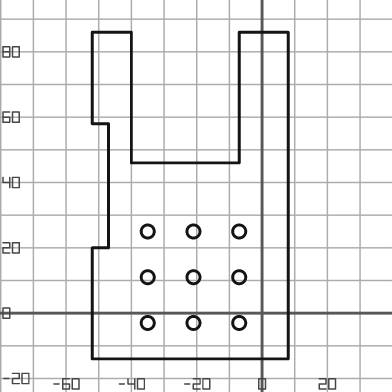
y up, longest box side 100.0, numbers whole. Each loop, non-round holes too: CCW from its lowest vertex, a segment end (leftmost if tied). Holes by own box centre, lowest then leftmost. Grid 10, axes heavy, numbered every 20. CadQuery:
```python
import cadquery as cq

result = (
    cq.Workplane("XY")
    .moveTo(-52.0, -14.0)
    .lineTo(8.0, -14.0)
    .lineTo(8.0, 86.0)
    .lineTo(-7.0, 86.0)
    .lineTo(-7.0, 46.0)
    .lineTo(-40.0, 46.0)
    .lineTo(-40.0, 86.0)
    .lineTo(-52.0, 86.0)
    .lineTo(-52.0, 58.0)
    .lineTo(-47.0, 58.0)
    .lineTo(-47.0, 20.0)
    .lineTo(-52.0, 20.0)
    .close()
    .moveTo(-35.0, -3.0)
    .circle(2.0)
    .moveTo(-21.0, -3.0)
    .circle(2.0)
    .moveTo(-7.0, -3.0)
    .circle(2.0)
    .moveTo(-35.0, 11.0)
    .circle(2.0)
    .moveTo(-21.0, 11.0)
    .circle(2.0)
    .moveTo(-7.0, 11.0)
    .circle(2.0)
    .moveTo(-35.0, 25.0)
    .circle(2.0)
    .moveTo(-21.0, 25.0)
    .circle(2.0)
    .moveTo(-7.0, 25.0)
    .circle(2.0)
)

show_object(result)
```